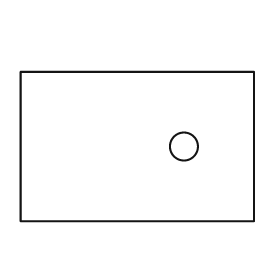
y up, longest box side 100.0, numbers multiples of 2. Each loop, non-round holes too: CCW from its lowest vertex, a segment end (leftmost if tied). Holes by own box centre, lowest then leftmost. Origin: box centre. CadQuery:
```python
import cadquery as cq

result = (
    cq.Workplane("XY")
    .moveTo(-50.0, -32.0)
    .lineTo(50.0, -32.0)
    .lineTo(50.0, 32.0)
    .lineTo(-50.0, 32.0)
    .close()
    .moveTo(20.0, 0.0)
    .circle(6.0)
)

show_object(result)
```